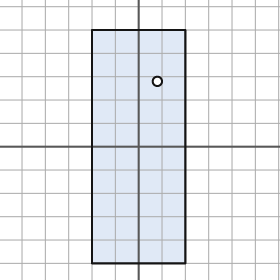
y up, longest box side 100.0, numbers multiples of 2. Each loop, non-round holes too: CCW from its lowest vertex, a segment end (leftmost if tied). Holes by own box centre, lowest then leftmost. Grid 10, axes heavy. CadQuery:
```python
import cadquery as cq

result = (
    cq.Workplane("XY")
    .moveTo(-20.0, -50.0)
    .lineTo(20.0, -50.0)
    .lineTo(20.0, 50.0)
    .lineTo(-20.0, 50.0)
    .close()
    .moveTo(8.0, 28.0)
    .circle(2.0)
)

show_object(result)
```